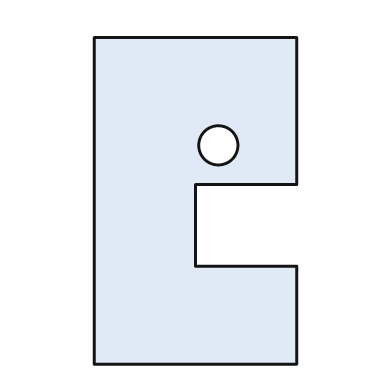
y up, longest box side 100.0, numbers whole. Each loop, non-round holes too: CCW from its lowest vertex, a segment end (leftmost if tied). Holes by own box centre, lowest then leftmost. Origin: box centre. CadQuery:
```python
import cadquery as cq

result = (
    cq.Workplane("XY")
    .moveTo(-31.0, -50.0)
    .lineTo(31.0, -50.0)
    .lineTo(31.0, -20.0)
    .lineTo(0.0, -20.0)
    .lineTo(0.0, 5.0)
    .lineTo(31.0, 5.0)
    .lineTo(31.0, 50.0)
    .lineTo(-31.0, 50.0)
    .close()
    .moveTo(7.0, 17.0)
    .circle(6.0)
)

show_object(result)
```